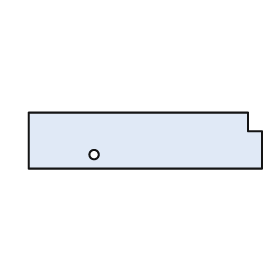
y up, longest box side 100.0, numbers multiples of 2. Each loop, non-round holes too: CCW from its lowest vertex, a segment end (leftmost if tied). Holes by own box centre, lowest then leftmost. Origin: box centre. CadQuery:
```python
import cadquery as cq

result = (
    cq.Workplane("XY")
    .moveTo(-50.0, -12.0)
    .lineTo(50.0, -12.0)
    .lineTo(50.0, 4.0)
    .lineTo(44.0, 4.0)
    .lineTo(44.0, 12.0)
    .lineTo(-50.0, 12.0)
    .close()
    .moveTo(-22.0, -6.0)
    .circle(2.0)
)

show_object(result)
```